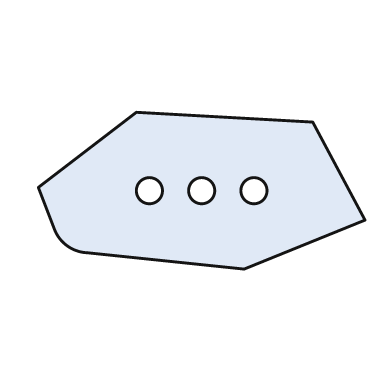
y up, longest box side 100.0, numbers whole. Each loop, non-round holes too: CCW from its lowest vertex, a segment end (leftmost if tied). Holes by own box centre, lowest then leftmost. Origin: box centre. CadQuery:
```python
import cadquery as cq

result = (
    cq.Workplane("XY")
    .moveTo(13.0, -24.0)
    .lineTo(50.0, -9.0)
    .lineTo(34.0, 21.0)
    .lineTo(-20.0, 24.0)
    .lineTo(-50.0, 1.0)
    .lineTo(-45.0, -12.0)
    .threePointArc((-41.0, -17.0), (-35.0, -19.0))
    .close()
    .moveTo(-16.0, 0.0)
    .circle(4.0)
    .moveTo(0.0, 0.0)
    .circle(4.0)
    .moveTo(16.0, 0.0)
    .circle(4.0)
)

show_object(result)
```